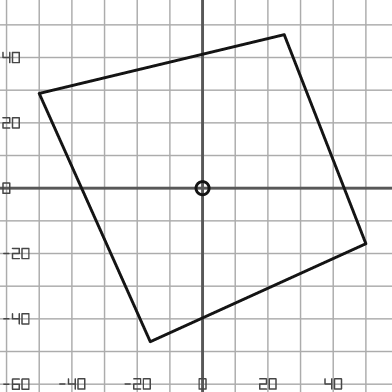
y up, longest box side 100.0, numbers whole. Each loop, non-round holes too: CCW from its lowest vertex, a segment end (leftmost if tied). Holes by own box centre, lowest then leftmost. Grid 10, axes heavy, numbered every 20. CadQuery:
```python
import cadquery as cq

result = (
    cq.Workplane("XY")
    .moveTo(-16.0, -47.0)
    .lineTo(50.0, -17.0)
    .lineTo(25.0, 47.0)
    .lineTo(-50.0, 29.0)
    .close()
    .moveTo(0.0, 0.0)
    .circle(2.0)
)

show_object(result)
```